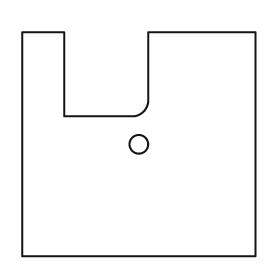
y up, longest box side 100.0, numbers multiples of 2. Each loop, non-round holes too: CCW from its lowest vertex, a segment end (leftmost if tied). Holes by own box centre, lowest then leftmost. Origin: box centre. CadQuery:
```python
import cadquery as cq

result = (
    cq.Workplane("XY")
    .moveTo(-50.0, -48.0)
    .lineTo(50.0, -48.0)
    .lineTo(50.0, 48.0)
    .lineTo(4.0, 48.0)
    .lineTo(4.0, 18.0)
    .threePointArc((2.0, 14.0), (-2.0, 12.0))
    .lineTo(-32.0, 12.0)
    .lineTo(-32.0, 48.0)
    .lineTo(-50.0, 48.0)
    .close()
    .moveTo(0.0, 0.0)
    .circle(4.0)
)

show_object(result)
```